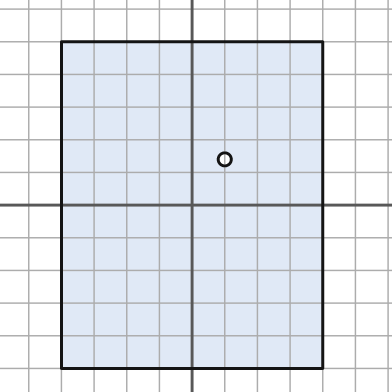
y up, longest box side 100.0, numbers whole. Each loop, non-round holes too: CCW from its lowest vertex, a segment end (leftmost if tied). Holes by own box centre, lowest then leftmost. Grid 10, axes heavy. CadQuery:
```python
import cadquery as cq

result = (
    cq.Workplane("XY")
    .moveTo(-40.0, -50.0)
    .lineTo(40.0, -50.0)
    .lineTo(40.0, 50.0)
    .lineTo(-40.0, 50.0)
    .close()
    .moveTo(10.0, 14.0)
    .circle(2.0)
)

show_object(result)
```